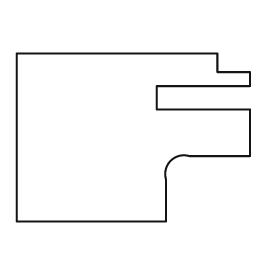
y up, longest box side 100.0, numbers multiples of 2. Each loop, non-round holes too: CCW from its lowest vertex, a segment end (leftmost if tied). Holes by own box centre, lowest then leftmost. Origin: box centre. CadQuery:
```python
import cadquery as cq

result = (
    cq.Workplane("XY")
    .moveTo(-50.0, -36.0)
    .lineTo(14.0, -36.0)
    .lineTo(14.0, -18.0)
    .threePointArc((16.0, -10.0), (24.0, -8.0))
    .lineTo(50.0, -8.0)
    .lineTo(50.0, 12.0)
    .lineTo(10.0, 12.0)
    .lineTo(10.0, 22.0)
    .lineTo(50.0, 22.0)
    .lineTo(50.0, 28.0)
    .lineTo(36.0, 28.0)
    .lineTo(36.0, 36.0)
    .lineTo(-50.0, 36.0)
    .close()
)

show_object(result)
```